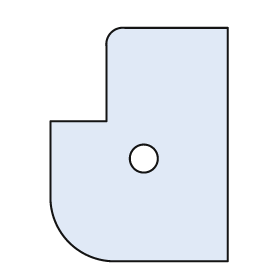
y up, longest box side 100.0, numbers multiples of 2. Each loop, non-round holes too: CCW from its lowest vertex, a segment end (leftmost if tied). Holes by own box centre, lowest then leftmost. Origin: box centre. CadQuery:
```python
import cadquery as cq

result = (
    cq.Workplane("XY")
    .moveTo(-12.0, -50.0)
    .lineTo(38.0, -50.0)
    .lineTo(38.0, 50.0)
    .lineTo(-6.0, 50.0)
    .threePointArc((-12.0, 48.0), (-14.0, 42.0))
    .lineTo(-14.0, 10.0)
    .lineTo(-38.0, 10.0)
    .lineTo(-38.0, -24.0)
    .threePointArc((-30.0, -42.0), (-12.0, -50.0))
    .close()
    .moveTo(2.0, -6.0)
    .circle(6.0)
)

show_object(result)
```